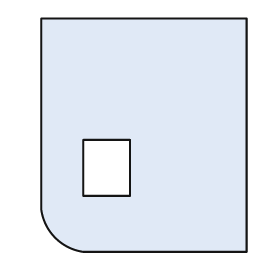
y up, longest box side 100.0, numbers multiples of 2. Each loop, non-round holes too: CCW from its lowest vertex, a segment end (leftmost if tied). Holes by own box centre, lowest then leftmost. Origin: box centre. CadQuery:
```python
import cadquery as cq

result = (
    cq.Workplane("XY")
    .moveTo(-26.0, -50.0)
    .lineTo(44.0, -50.0)
    .lineTo(44.0, 50.0)
    .lineTo(-44.0, 50.0)
    .lineTo(-44.0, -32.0)
    .threePointArc((-38.0, -44.0), (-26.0, -50.0))
    .close()
    .moveTo(-26.0, -26.0)
    .lineTo(-6.0, -26.0)
    .lineTo(-6.0, -2.0)
    .lineTo(-26.0, -2.0)
    .close()
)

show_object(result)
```